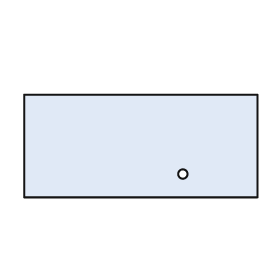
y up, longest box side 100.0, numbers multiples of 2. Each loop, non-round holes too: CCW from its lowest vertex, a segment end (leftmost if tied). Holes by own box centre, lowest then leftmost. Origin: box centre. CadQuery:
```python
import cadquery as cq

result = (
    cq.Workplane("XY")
    .moveTo(-50.0, -22.0)
    .lineTo(50.0, -22.0)
    .lineTo(50.0, 22.0)
    .lineTo(-50.0, 22.0)
    .close()
    .moveTo(18.0, -12.0)
    .circle(2.0)
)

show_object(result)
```